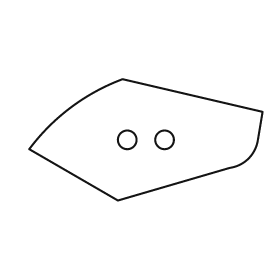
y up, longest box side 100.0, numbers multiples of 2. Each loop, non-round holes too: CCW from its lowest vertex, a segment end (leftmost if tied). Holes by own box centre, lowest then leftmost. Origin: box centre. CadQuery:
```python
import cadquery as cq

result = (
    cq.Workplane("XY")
    .moveTo(-12.0, -26.0)
    .lineTo(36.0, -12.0)
    .threePointArc((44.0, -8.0), (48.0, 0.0))
    .lineTo(50.0, 12.0)
    .lineTo(-10.0, 26.0)
    .threePointArc((-32.0, 14.0), (-50.0, -4.0))
    .close()
    .moveTo(-8.0, 0.0)
    .circle(4.0)
    .moveTo(8.0, 0.0)
    .circle(4.0)
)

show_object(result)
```